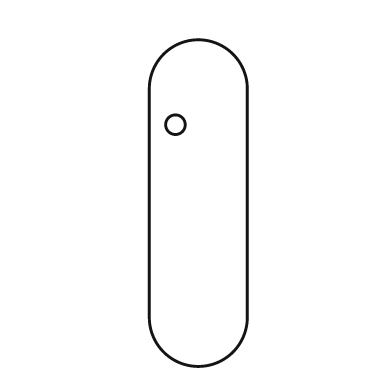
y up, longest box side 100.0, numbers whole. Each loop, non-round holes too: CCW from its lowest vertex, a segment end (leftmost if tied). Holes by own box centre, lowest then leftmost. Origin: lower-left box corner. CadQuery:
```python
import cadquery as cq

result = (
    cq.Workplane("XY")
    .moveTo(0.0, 15.0)
    .threePointArc((15.0, 0.0), (30.0, 15.0))
    .lineTo(30.0, 85.0)
    .threePointArc((15.0, 100.0), (0.0, 85.0))
    .close()
    .moveTo(8.0, 74.0)
    .circle(3.0)
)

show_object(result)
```